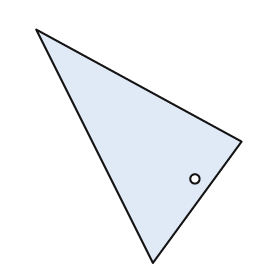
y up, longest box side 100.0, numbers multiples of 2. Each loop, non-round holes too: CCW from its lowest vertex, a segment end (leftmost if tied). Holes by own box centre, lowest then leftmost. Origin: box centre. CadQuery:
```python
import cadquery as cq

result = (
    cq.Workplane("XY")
    .moveTo(6.0, -50.0)
    .lineTo(44.0, 2.0)
    .lineTo(-44.0, 50.0)
    .close()
    .moveTo(24.0, -14.0)
    .circle(2.0)
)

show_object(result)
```